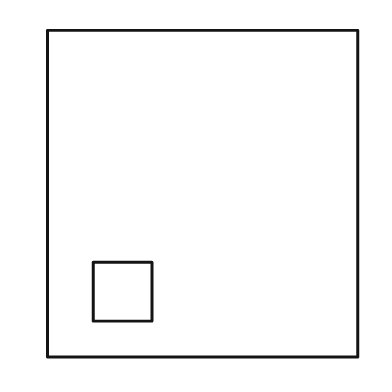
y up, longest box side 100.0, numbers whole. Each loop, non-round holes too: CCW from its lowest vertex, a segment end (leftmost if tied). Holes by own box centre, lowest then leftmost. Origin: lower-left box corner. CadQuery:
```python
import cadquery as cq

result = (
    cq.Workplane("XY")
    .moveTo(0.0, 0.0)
    .lineTo(95.0, 0.0)
    .lineTo(95.0, 100.0)
    .lineTo(0.0, 100.0)
    .close()
    .moveTo(14.0, 11.0)
    .lineTo(32.0, 11.0)
    .lineTo(32.0, 29.0)
    .lineTo(14.0, 29.0)
    .close()
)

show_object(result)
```